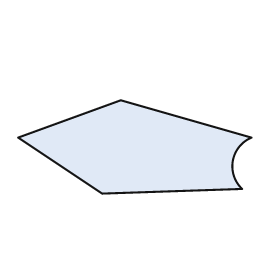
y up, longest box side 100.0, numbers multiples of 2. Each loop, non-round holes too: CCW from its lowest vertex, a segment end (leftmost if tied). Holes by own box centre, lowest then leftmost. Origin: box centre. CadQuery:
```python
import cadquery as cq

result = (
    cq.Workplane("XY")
    .moveTo(-14.0, -20.0)
    .lineTo(46.0, -18.0)
    .threePointArc((42.0, -6.0), (50.0, 4.0))
    .lineTo(-6.0, 20.0)
    .lineTo(-50.0, 4.0)
    .close()
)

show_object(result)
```